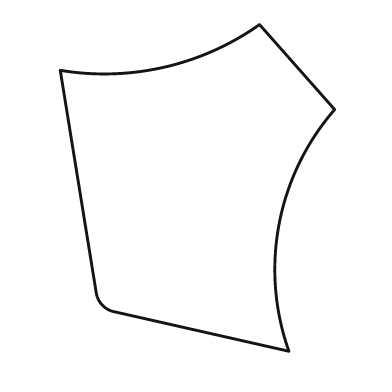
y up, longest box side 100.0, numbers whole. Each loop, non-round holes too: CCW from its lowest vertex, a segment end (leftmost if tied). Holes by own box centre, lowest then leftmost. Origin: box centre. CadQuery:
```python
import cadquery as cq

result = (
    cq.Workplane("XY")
    .moveTo(28.0, -50.0)
    .threePointArc((25.0, -11.0), (42.0, 24.0))
    .lineTo(19.0, 50.0)
    .threePointArc((-10.0, 37.0), (-42.0, 36.0))
    .lineTo(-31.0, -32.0)
    .threePointArc((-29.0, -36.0), (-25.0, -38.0))
    .close()
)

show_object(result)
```